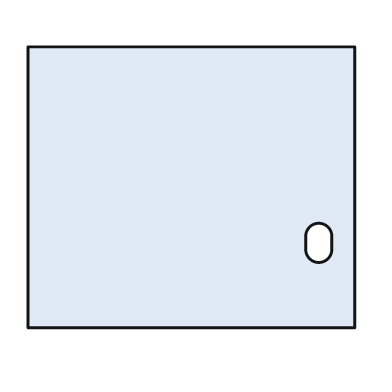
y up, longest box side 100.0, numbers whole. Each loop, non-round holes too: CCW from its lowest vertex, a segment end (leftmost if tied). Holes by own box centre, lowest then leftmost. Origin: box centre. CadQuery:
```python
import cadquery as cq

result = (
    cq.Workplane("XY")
    .moveTo(-50.0, -43.0)
    .lineTo(50.0, -43.0)
    .lineTo(50.0, 43.0)
    .lineTo(-50.0, 43.0)
    .close()
    .moveTo(35.0, -19.0)
    .threePointArc((39.0, -23.0), (43.0, -19.0))
    .lineTo(43.0, -15.0)
    .threePointArc((39.0, -11.0), (35.0, -15.0))
    .close()
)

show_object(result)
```